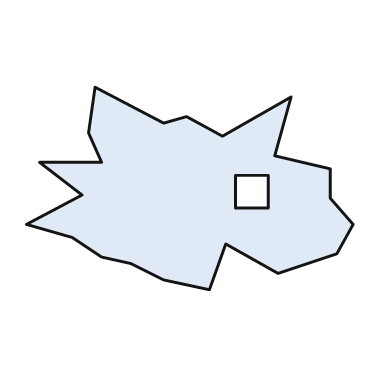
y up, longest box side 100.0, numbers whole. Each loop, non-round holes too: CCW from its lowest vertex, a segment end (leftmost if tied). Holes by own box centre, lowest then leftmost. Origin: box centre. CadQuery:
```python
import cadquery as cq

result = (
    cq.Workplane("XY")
    .moveTo(6.0, -31.0)
    .lineTo(11.0, -17.0)
    .lineTo(27.0, -26.0)
    .lineTo(45.0, -20.0)
    .lineTo(50.0, -11.0)
    .lineTo(43.0, -3.0)
    .lineTo(43.0, 6.0)
    .lineTo(26.0, 10.0)
    .lineTo(31.0, 28.0)
    .lineTo(10.0, 16.0)
    .lineTo(-1.0, 22.0)
    .lineTo(-8.0, 20.0)
    .lineTo(-29.0, 31.0)
    .lineTo(-31.0, 17.0)
    .lineTo(-27.0, 8.0)
    .lineTo(-46.0, 8.0)
    .lineTo(-33.0, -2.0)
    .lineTo(-50.0, -11.0)
    .lineTo(-36.0, -15.0)
    .lineTo(-27.0, -21.0)
    .lineTo(-18.0, -23.0)
    .lineTo(-8.0, -28.0)
    .close()
    .moveTo(14.0, -6.0)
    .lineTo(24.0, -6.0)
    .lineTo(24.0, 4.0)
    .lineTo(14.0, 4.0)
    .close()
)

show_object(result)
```